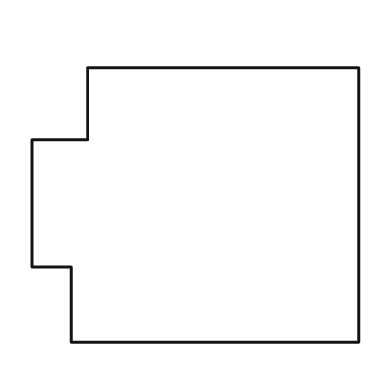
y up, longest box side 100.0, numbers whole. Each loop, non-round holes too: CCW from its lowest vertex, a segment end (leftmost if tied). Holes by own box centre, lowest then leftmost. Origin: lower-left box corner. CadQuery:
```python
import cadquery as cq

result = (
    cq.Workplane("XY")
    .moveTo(12.0, 0.0)
    .lineTo(100.0, 0.0)
    .lineTo(100.0, 84.0)
    .lineTo(17.0, 84.0)
    .lineTo(17.0, 62.0)
    .lineTo(0.0, 62.0)
    .lineTo(0.0, 23.0)
    .lineTo(12.0, 23.0)
    .close()
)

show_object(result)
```